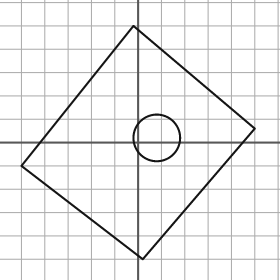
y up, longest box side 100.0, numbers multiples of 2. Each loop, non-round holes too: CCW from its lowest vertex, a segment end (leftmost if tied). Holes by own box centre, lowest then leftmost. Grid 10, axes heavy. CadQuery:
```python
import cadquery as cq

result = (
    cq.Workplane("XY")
    .moveTo(2.0, -50.0)
    .lineTo(50.0, 6.0)
    .lineTo(-2.0, 50.0)
    .lineTo(-50.0, -10.0)
    .close()
    .moveTo(8.0, 2.0)
    .circle(10.0)
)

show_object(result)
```